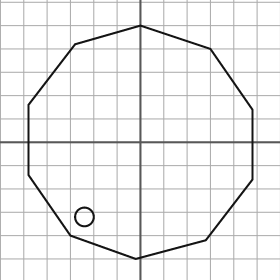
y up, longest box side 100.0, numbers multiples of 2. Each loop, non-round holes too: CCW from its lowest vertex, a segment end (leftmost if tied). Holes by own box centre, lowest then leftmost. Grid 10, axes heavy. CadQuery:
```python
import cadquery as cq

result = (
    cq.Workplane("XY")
    .moveTo(-2.0, -50.0)
    .lineTo(28.0, -42.0)
    .lineTo(48.0, -16.0)
    .lineTo(48.0, 14.0)
    .lineTo(30.0, 40.0)
    .lineTo(0.0, 50.0)
    .lineTo(-28.0, 42.0)
    .lineTo(-48.0, 16.0)
    .lineTo(-48.0, -14.0)
    .lineTo(-30.0, -40.0)
    .close()
    .moveTo(-24.0, -32.0)
    .circle(4.0)
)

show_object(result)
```